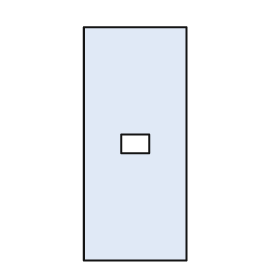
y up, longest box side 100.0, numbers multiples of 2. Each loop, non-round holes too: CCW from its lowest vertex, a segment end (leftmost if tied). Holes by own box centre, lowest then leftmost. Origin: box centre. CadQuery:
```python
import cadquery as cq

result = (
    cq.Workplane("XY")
    .moveTo(-22.0, -50.0)
    .lineTo(22.0, -50.0)
    .lineTo(22.0, 50.0)
    .lineTo(-22.0, 50.0)
    .close()
    .moveTo(-6.0, -4.0)
    .lineTo(6.0, -4.0)
    .lineTo(6.0, 4.0)
    .lineTo(-6.0, 4.0)
    .close()
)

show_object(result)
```